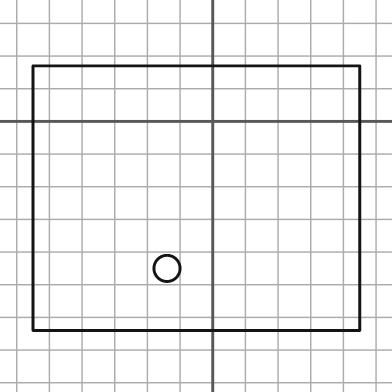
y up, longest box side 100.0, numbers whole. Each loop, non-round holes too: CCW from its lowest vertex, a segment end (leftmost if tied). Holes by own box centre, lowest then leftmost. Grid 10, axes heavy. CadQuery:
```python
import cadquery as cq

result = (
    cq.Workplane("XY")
    .moveTo(-55.0, -64.0)
    .lineTo(45.0, -64.0)
    .lineTo(45.0, 17.0)
    .lineTo(-55.0, 17.0)
    .close()
    .moveTo(-14.0, -45.0)
    .circle(4.0)
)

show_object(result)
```